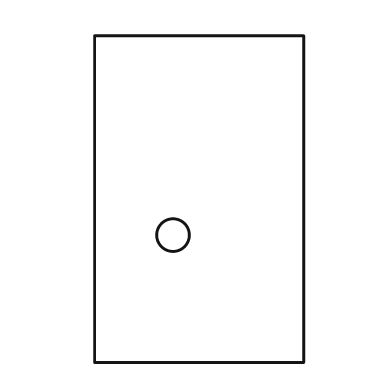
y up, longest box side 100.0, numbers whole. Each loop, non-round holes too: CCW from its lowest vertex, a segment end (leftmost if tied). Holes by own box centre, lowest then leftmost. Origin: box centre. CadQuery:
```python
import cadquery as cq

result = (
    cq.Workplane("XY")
    .moveTo(-32.0, -50.0)
    .lineTo(32.0, -50.0)
    .lineTo(32.0, 50.0)
    .lineTo(-32.0, 50.0)
    .close()
    .moveTo(-8.0, -11.0)
    .circle(5.0)
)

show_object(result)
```